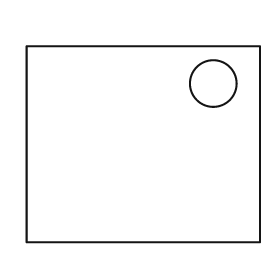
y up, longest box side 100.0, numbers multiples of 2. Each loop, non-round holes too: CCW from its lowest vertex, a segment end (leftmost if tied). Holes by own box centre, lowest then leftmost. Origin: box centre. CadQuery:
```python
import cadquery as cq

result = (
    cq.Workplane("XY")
    .moveTo(-50.0, -42.0)
    .lineTo(50.0, -42.0)
    .lineTo(50.0, 42.0)
    .lineTo(-50.0, 42.0)
    .close()
    .moveTo(30.0, 26.0)
    .circle(10.0)
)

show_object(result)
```